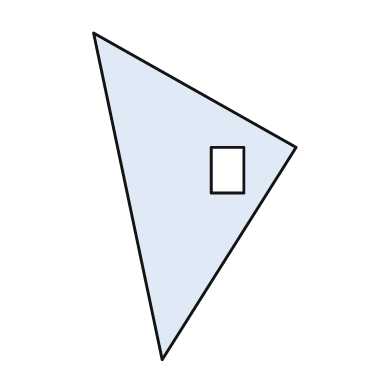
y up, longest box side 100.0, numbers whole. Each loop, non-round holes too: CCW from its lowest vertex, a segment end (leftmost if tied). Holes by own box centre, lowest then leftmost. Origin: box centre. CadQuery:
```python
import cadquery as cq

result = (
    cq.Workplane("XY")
    .moveTo(-10.0, -50.0)
    .lineTo(31.0, 15.0)
    .lineTo(-31.0, 50.0)
    .close()
    .moveTo(5.0, 1.0)
    .lineTo(15.0, 1.0)
    .lineTo(15.0, 15.0)
    .lineTo(5.0, 15.0)
    .close()
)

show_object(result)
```